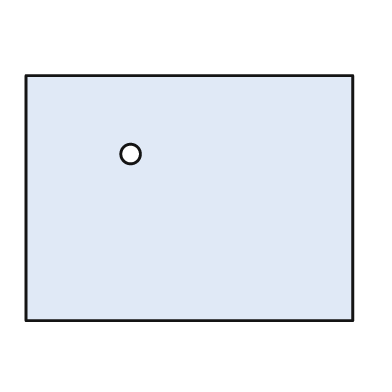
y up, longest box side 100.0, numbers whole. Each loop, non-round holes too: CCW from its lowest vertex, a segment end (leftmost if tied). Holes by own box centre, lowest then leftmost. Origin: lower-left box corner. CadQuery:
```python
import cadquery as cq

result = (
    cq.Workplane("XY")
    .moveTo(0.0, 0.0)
    .lineTo(100.0, 0.0)
    .lineTo(100.0, 75.0)
    .lineTo(0.0, 75.0)
    .close()
    .moveTo(32.0, 51.0)
    .circle(3.0)
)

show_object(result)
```